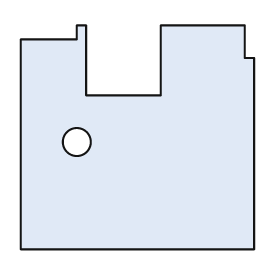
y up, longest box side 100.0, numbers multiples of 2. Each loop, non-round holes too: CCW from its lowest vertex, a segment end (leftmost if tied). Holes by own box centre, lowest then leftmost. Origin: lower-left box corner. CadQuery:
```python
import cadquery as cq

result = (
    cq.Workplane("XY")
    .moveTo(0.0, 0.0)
    .lineTo(100.0, 0.0)
    .lineTo(100.0, 82.0)
    .lineTo(96.0, 82.0)
    .lineTo(96.0, 96.0)
    .lineTo(60.0, 96.0)
    .lineTo(60.0, 66.0)
    .lineTo(28.0, 66.0)
    .lineTo(28.0, 96.0)
    .lineTo(24.0, 96.0)
    .lineTo(24.0, 90.0)
    .lineTo(0.0, 90.0)
    .close()
    .moveTo(24.0, 46.0)
    .circle(6.0)
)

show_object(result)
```